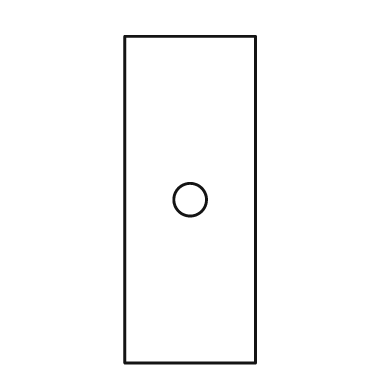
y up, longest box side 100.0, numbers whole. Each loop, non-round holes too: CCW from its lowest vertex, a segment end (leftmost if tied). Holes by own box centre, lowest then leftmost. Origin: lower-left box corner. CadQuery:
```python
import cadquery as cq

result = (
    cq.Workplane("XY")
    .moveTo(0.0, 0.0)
    .lineTo(40.0, 0.0)
    .lineTo(40.0, 100.0)
    .lineTo(0.0, 100.0)
    .close()
    .moveTo(20.0, 50.0)
    .circle(5.0)
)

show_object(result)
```